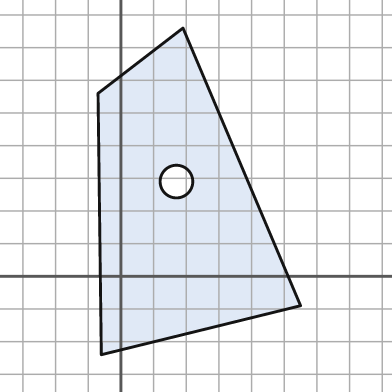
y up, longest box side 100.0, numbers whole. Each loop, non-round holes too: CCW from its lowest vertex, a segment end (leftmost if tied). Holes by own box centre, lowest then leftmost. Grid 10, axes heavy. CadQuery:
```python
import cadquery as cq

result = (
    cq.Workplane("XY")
    .moveTo(-6.0, -24.0)
    .lineTo(55.0, -9.0)
    .lineTo(19.0, 76.0)
    .lineTo(-7.0, 56.0)
    .close()
    .moveTo(17.0, 29.0)
    .circle(5.0)
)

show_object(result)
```